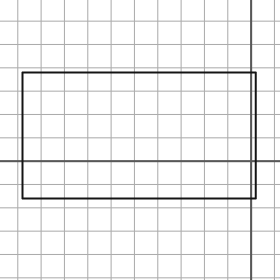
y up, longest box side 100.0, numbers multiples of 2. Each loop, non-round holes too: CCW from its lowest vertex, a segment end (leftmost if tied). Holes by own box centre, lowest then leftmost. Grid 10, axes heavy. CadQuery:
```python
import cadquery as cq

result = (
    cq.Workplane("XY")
    .moveTo(-98.0, -16.0)
    .lineTo(2.0, -16.0)
    .lineTo(2.0, 38.0)
    .lineTo(-98.0, 38.0)
    .close()
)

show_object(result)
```